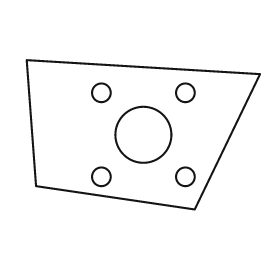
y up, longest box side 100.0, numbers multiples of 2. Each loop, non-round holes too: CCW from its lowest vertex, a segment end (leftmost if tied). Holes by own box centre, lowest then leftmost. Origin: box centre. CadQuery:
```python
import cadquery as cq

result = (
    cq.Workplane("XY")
    .moveTo(22.0, -32.0)
    .lineTo(50.0, 26.0)
    .lineTo(-50.0, 32.0)
    .lineTo(-46.0, -22.0)
    .close()
    .moveTo(-18.0, -18.0)
    .circle(4.0)
    .moveTo(18.0, -18.0)
    .circle(4.0)
    .moveTo(0.0, 0.0)
    .circle(12.0)
    .moveTo(-18.0, 18.0)
    .circle(4.0)
    .moveTo(18.0, 18.0)
    .circle(4.0)
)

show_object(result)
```